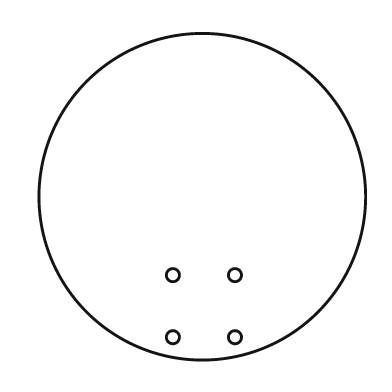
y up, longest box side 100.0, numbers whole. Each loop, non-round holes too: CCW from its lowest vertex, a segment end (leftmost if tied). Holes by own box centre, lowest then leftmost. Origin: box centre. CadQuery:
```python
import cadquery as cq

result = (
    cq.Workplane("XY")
    .moveTo(0.0, 0.0)
    .circle(50.0)
    .moveTo(-9.0, -43.0)
    .circle(2.0)
    .moveTo(10.0, -43.0)
    .circle(2.0)
    .moveTo(-9.0, -24.0)
    .circle(2.0)
    .moveTo(10.0, -24.0)
    .circle(2.0)
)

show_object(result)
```